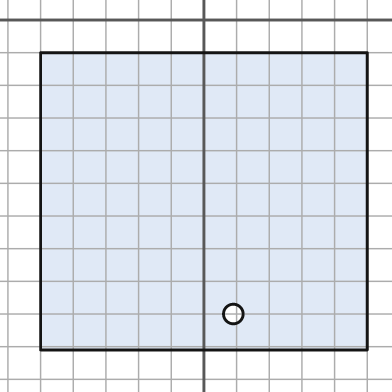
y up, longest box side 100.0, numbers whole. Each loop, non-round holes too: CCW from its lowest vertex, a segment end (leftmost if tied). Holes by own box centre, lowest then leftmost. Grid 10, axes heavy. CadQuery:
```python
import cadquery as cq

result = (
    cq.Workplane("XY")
    .moveTo(-50.0, -101.0)
    .lineTo(50.0, -101.0)
    .lineTo(50.0, -10.0)
    .lineTo(-50.0, -10.0)
    .close()
    .moveTo(9.0, -90.0)
    .circle(3.0)
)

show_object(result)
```